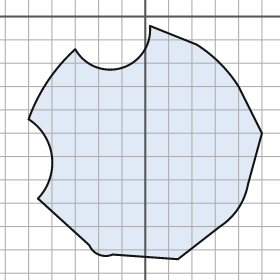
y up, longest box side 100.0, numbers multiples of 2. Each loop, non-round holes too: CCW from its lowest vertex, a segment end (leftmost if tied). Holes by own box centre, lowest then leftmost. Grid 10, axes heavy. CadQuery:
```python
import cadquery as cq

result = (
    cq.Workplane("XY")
    .moveTo(14.0, -104.0)
    .lineTo(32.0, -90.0)
    .threePointArc((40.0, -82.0), (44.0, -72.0))
    .lineTo(50.0, -50.0)
    .lineTo(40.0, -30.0)
    .threePointArc((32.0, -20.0), (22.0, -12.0))
    .lineTo(2.0, -4.0)
    .threePointArc((-10.0, -22.0), (-30.0, -14.0))
    .threePointArc((-42.0, -28.0), (-50.0, -44.0))
    .threePointArc((-40.0, -60.0), (-46.0, -78.0))
    .lineTo(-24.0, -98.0)
    .threePointArc((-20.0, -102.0), (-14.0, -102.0))
    .close()
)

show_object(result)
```